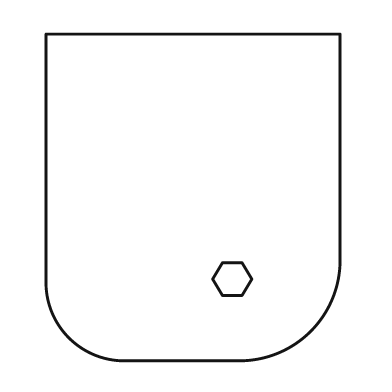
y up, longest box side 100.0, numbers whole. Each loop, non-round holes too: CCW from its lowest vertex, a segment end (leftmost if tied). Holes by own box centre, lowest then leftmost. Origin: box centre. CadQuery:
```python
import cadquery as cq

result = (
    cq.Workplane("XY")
    .moveTo(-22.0, -50.0)
    .lineTo(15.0, -50.0)
    .threePointArc((36.0, -41.0), (45.0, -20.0))
    .lineTo(45.0, 50.0)
    .lineTo(-45.0, 50.0)
    .lineTo(-45.0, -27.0)
    .threePointArc((-38.0, -43.0), (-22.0, -50.0))
    .close()
    .moveTo(9.0, -30.0)
    .lineTo(15.0, -30.0)
    .lineTo(18.0, -25.0)
    .lineTo(15.0, -20.0)
    .lineTo(9.0, -20.0)
    .lineTo(6.0, -25.0)
    .close()
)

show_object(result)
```